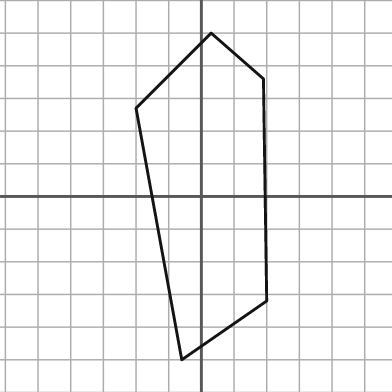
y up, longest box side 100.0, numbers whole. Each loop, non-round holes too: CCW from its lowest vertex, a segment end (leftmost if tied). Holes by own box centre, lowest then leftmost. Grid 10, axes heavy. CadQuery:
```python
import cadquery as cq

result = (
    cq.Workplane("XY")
    .moveTo(-6.0, -50.0)
    .lineTo(20.0, -32.0)
    .lineTo(19.0, 36.0)
    .lineTo(3.0, 50.0)
    .lineTo(-20.0, 27.0)
    .close()
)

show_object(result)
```